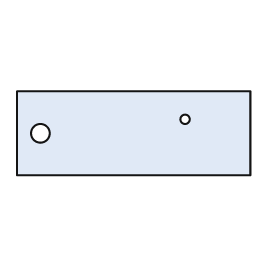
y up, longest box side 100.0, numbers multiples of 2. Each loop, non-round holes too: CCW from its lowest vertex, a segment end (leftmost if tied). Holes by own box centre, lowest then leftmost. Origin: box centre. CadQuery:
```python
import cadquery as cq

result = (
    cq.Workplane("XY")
    .moveTo(-50.0, -18.0)
    .lineTo(50.0, -18.0)
    .lineTo(50.0, 18.0)
    .lineTo(-50.0, 18.0)
    .close()
    .moveTo(-40.0, 0.0)
    .circle(4.0)
    .moveTo(22.0, 6.0)
    .circle(2.0)
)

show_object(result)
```